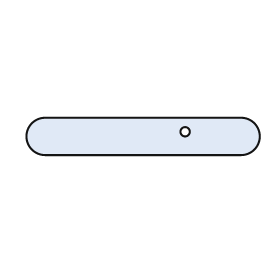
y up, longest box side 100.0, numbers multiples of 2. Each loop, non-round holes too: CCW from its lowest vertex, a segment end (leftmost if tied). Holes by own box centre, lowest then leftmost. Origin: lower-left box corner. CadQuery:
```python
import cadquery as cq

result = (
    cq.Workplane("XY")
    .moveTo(8.0, 0.0)
    .lineTo(92.0, 0.0)
    .threePointArc((100.0, 8.0), (92.0, 16.0))
    .lineTo(8.0, 16.0)
    .threePointArc((0.0, 8.0), (8.0, 0.0))
    .close()
    .moveTo(68.0, 10.0)
    .circle(2.0)
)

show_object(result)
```